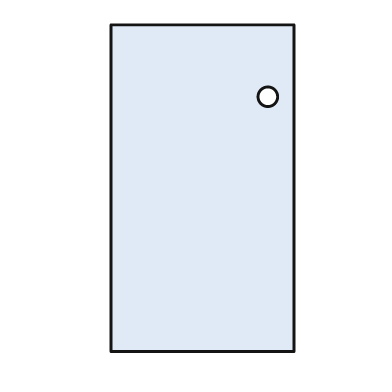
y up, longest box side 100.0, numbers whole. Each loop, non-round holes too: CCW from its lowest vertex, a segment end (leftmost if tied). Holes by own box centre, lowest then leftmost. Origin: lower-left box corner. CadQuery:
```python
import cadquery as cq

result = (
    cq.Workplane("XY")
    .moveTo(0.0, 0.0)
    .lineTo(56.0, 0.0)
    .lineTo(56.0, 100.0)
    .lineTo(0.0, 100.0)
    .close()
    .moveTo(48.0, 78.0)
    .circle(3.0)
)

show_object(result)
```